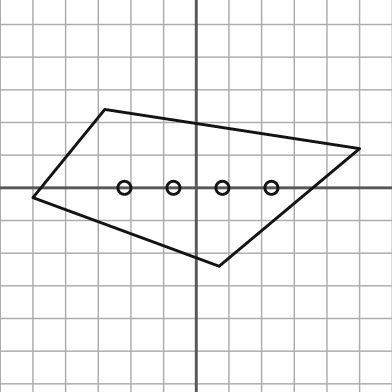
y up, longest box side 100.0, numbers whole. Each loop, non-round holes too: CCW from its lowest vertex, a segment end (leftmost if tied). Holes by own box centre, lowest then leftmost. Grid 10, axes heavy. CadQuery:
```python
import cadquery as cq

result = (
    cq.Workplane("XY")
    .moveTo(7.0, -24.0)
    .lineTo(50.0, 12.0)
    .lineTo(-28.0, 24.0)
    .lineTo(-50.0, -3.0)
    .close()
    .moveTo(-22.0, 0.0)
    .circle(2.0)
    .moveTo(-7.0, 0.0)
    .circle(2.0)
    .moveTo(8.0, 0.0)
    .circle(2.0)
    .moveTo(23.0, 0.0)
    .circle(2.0)
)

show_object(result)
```